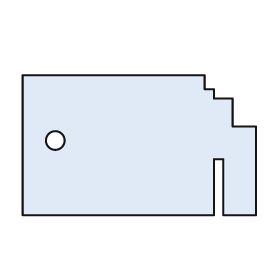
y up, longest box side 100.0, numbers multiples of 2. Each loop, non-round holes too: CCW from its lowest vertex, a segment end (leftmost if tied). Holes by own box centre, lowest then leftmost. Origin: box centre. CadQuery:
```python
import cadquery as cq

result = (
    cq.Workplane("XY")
    .moveTo(-50.0, -30.0)
    .lineTo(32.0, -30.0)
    .lineTo(32.0, -6.0)
    .lineTo(36.0, -6.0)
    .lineTo(36.0, -30.0)
    .lineTo(50.0, -30.0)
    .lineTo(50.0, 8.0)
    .lineTo(40.0, 8.0)
    .lineTo(40.0, 20.0)
    .lineTo(32.0, 20.0)
    .lineTo(32.0, 24.0)
    .lineTo(28.0, 24.0)
    .lineTo(28.0, 30.0)
    .lineTo(-50.0, 30.0)
    .close()
    .moveTo(-36.0, 2.0)
    .circle(4.0)
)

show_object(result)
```